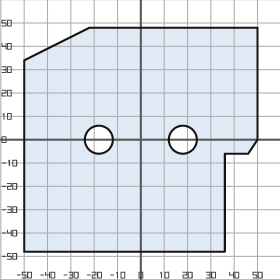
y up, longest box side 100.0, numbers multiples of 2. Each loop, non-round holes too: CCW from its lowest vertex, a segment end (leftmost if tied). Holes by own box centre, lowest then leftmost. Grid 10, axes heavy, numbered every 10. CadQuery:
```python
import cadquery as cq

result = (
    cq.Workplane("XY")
    .moveTo(-50.0, -48.0)
    .lineTo(36.0, -48.0)
    .lineTo(36.0, -6.0)
    .lineTo(46.0, -6.0)
    .lineTo(50.0, 0.0)
    .lineTo(50.0, 48.0)
    .lineTo(-22.0, 48.0)
    .lineTo(-50.0, 34.0)
    .close()
    .moveTo(-18.0, 0.0)
    .circle(6.0)
    .moveTo(18.0, 0.0)
    .circle(6.0)
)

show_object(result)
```